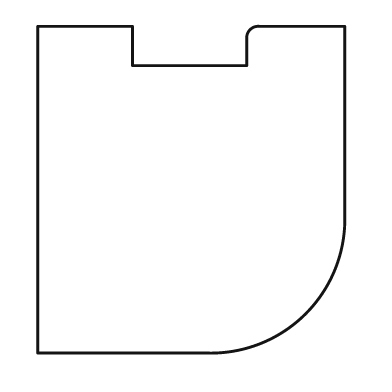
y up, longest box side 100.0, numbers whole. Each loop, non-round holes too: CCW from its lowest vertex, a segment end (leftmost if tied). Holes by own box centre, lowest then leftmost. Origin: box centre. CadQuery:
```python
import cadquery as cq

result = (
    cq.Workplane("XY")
    .moveTo(-47.0, -50.0)
    .lineTo(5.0, -50.0)
    .threePointArc((35.0, -38.0), (47.0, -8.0))
    .lineTo(47.0, 50.0)
    .lineTo(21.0, 50.0)
    .threePointArc((18.0, 49.0), (17.0, 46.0))
    .lineTo(17.0, 38.0)
    .lineTo(-18.0, 38.0)
    .lineTo(-18.0, 50.0)
    .lineTo(-47.0, 50.0)
    .close()
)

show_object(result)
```